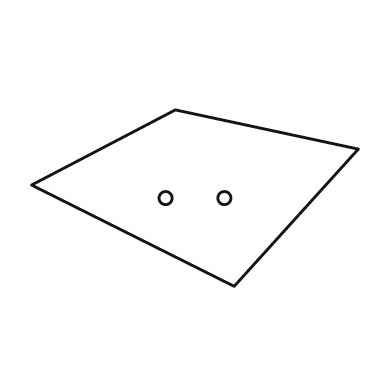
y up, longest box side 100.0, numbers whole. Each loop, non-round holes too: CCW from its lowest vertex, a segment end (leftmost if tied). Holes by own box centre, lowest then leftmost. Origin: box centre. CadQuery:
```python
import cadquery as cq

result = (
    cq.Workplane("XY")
    .moveTo(12.0, -27.0)
    .lineTo(50.0, 15.0)
    .lineTo(-6.0, 27.0)
    .lineTo(-50.0, 4.0)
    .close()
    .moveTo(-9.0, 0.0)
    .circle(2.0)
    .moveTo(9.0, 0.0)
    .circle(2.0)
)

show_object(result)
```